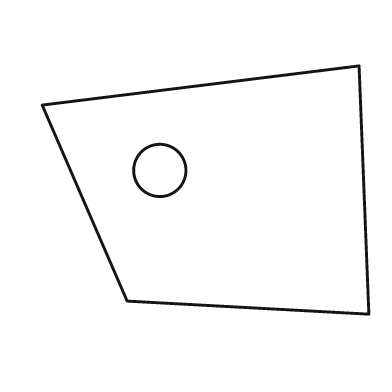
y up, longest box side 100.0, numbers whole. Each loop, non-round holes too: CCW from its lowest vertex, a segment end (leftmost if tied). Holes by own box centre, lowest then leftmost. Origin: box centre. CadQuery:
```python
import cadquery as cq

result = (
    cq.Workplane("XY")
    .moveTo(50.0, -38.0)
    .lineTo(47.0, 38.0)
    .lineTo(-50.0, 26.0)
    .lineTo(-24.0, -34.0)
    .close()
    .moveTo(-14.0, 6.0)
    .circle(8.0)
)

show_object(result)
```